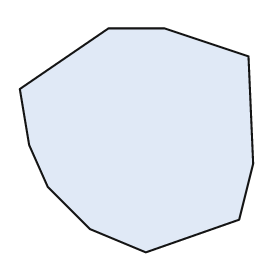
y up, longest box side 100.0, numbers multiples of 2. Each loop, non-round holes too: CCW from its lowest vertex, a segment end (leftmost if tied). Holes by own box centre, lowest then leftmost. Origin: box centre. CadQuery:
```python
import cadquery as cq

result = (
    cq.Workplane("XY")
    .moveTo(4.0, -48.0)
    .lineTo(44.0, -34.0)
    .lineTo(50.0, -10.0)
    .lineTo(48.0, 36.0)
    .lineTo(12.0, 48.0)
    .lineTo(-12.0, 48.0)
    .lineTo(-50.0, 22.0)
    .lineTo(-46.0, -2.0)
    .lineTo(-38.0, -20.0)
    .lineTo(-20.0, -38.0)
    .close()
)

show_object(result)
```